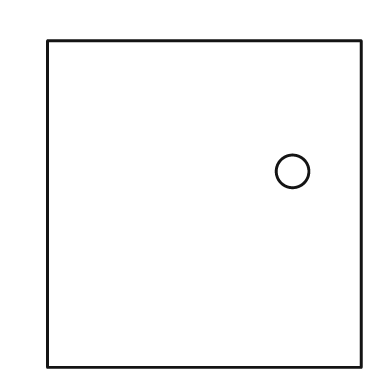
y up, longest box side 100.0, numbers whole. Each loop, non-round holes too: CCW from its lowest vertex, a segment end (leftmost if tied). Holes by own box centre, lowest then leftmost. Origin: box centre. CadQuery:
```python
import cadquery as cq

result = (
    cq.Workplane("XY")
    .moveTo(-48.0, -50.0)
    .lineTo(48.0, -50.0)
    .lineTo(48.0, 50.0)
    .lineTo(-48.0, 50.0)
    .close()
    .moveTo(27.0, 10.0)
    .circle(5.0)
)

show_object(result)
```